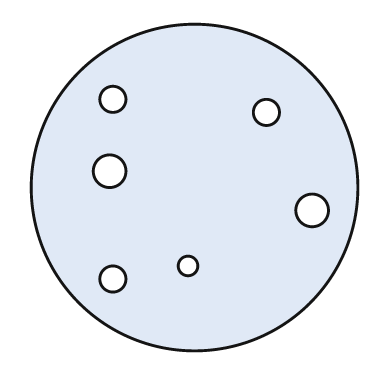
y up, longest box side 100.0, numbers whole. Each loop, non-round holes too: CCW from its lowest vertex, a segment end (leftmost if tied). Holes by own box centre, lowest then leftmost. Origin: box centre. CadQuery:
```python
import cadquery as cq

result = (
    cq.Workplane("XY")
    .moveTo(0.0, 0.0)
    .circle(50.0)
    .moveTo(-25.0, -28.0)
    .circle(4.0)
    .moveTo(-2.0, -24.0)
    .circle(3.0)
    .moveTo(36.0, -7.0)
    .circle(5.0)
    .moveTo(-26.0, 5.0)
    .circle(5.0)
    .moveTo(22.0, 23.0)
    .circle(4.0)
    .moveTo(-25.0, 27.0)
    .circle(4.0)
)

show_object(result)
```